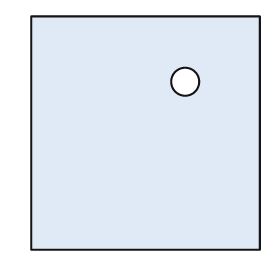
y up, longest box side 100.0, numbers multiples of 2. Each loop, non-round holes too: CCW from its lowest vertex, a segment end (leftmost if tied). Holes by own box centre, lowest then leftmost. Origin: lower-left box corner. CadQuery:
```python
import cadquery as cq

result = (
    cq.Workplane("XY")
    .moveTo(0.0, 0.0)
    .lineTo(98.0, 0.0)
    .lineTo(98.0, 100.0)
    .lineTo(0.0, 100.0)
    .close()
    .moveTo(66.0, 72.0)
    .circle(6.0)
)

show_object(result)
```